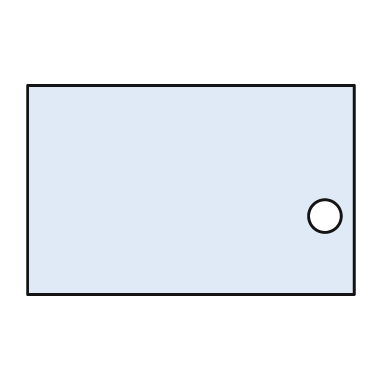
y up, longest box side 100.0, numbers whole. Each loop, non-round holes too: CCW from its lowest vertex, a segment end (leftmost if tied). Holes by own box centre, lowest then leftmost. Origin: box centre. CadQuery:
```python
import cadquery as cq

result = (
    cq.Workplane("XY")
    .moveTo(-50.0, -32.0)
    .lineTo(50.0, -32.0)
    .lineTo(50.0, 32.0)
    .lineTo(-50.0, 32.0)
    .close()
    .moveTo(41.0, -8.0)
    .circle(5.0)
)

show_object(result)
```